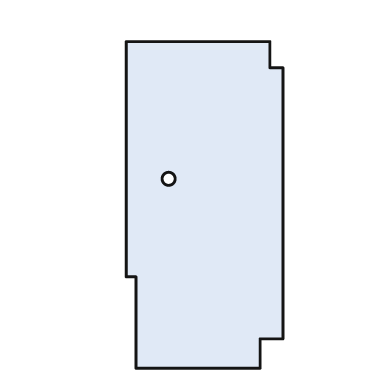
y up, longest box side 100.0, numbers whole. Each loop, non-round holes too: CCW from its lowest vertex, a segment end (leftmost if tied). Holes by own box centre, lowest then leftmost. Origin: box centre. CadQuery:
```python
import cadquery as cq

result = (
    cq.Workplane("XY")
    .moveTo(-21.0, -50.0)
    .lineTo(17.0, -50.0)
    .lineTo(17.0, -41.0)
    .lineTo(24.0, -41.0)
    .lineTo(24.0, 42.0)
    .lineTo(20.0, 42.0)
    .lineTo(20.0, 50.0)
    .lineTo(-24.0, 50.0)
    .lineTo(-24.0, -22.0)
    .lineTo(-21.0, -22.0)
    .close()
    .moveTo(-11.0, 8.0)
    .circle(2.0)
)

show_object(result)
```